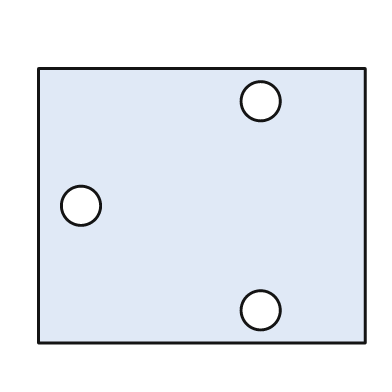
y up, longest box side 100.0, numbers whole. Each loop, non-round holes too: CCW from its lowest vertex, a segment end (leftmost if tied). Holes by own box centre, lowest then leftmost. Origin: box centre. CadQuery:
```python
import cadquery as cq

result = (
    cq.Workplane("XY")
    .moveTo(-50.0, -42.0)
    .lineTo(50.0, -42.0)
    .lineTo(50.0, 42.0)
    .lineTo(-50.0, 42.0)
    .close()
    .moveTo(18.0, -32.0)
    .circle(6.0)
    .moveTo(-37.0, 0.0)
    .circle(6.0)
    .moveTo(18.0, 32.0)
    .circle(6.0)
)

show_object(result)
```